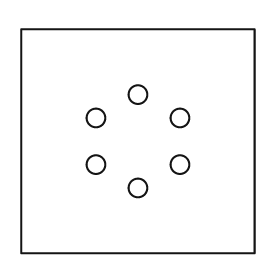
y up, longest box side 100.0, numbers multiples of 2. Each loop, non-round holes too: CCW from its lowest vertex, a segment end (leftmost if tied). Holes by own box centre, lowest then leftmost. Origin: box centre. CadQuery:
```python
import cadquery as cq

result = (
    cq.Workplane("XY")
    .moveTo(-50.0, -48.0)
    .lineTo(50.0, -48.0)
    .lineTo(50.0, 48.0)
    .lineTo(-50.0, 48.0)
    .close()
    .moveTo(0.0, -20.0)
    .circle(4.0)
    .moveTo(-18.0, -10.0)
    .circle(4.0)
    .moveTo(18.0, -10.0)
    .circle(4.0)
    .moveTo(-18.0, 10.0)
    .circle(4.0)
    .moveTo(18.0, 10.0)
    .circle(4.0)
    .moveTo(0.0, 20.0)
    .circle(4.0)
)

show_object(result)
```